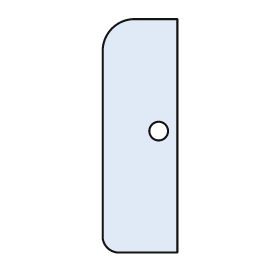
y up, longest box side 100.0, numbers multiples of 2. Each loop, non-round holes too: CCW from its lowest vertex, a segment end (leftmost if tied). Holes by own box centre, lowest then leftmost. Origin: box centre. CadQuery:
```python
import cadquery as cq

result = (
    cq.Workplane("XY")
    .moveTo(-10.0, -50.0)
    .lineTo(16.0, -50.0)
    .lineTo(16.0, 50.0)
    .lineTo(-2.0, 50.0)
    .threePointArc((-12.0, 46.0), (-16.0, 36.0))
    .lineTo(-16.0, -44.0)
    .threePointArc((-14.0, -48.0), (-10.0, -50.0))
    .close()
    .moveTo(8.0, 2.0)
    .circle(4.0)
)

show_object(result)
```